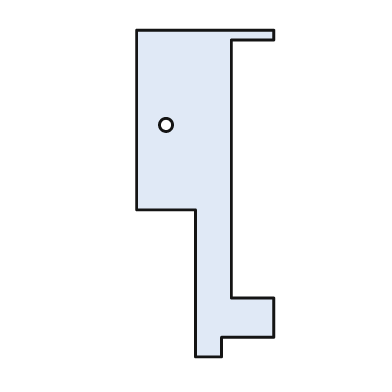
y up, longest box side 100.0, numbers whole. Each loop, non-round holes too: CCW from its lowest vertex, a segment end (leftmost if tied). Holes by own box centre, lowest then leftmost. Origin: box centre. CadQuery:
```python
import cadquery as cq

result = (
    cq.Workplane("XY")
    .moveTo(-3.0, -50.0)
    .lineTo(5.0, -50.0)
    .lineTo(5.0, -44.0)
    .lineTo(21.0, -44.0)
    .lineTo(21.0, -32.0)
    .lineTo(8.0, -32.0)
    .lineTo(8.0, 47.0)
    .lineTo(21.0, 47.0)
    .lineTo(21.0, 50.0)
    .lineTo(-21.0, 50.0)
    .lineTo(-21.0, -5.0)
    .lineTo(-3.0, -5.0)
    .close()
    .moveTo(-12.0, 21.0)
    .circle(2.0)
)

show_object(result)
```